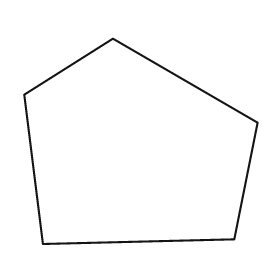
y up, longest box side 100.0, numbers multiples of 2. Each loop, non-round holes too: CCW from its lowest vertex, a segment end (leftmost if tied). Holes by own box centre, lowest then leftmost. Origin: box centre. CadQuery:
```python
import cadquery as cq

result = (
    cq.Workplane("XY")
    .moveTo(-42.0, -44.0)
    .lineTo(40.0, -42.0)
    .lineTo(50.0, 8.0)
    .lineTo(-12.0, 44.0)
    .lineTo(-50.0, 20.0)
    .close()
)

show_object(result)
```